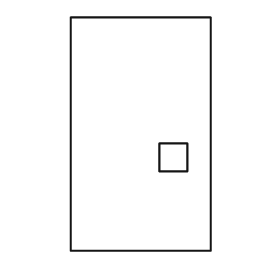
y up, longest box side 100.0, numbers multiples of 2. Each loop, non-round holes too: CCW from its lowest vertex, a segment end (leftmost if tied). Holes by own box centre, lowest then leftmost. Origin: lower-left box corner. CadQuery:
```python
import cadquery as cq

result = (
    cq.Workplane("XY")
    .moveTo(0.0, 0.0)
    .lineTo(60.0, 0.0)
    .lineTo(60.0, 100.0)
    .lineTo(0.0, 100.0)
    .close()
    .moveTo(38.0, 34.0)
    .lineTo(50.0, 34.0)
    .lineTo(50.0, 46.0)
    .lineTo(38.0, 46.0)
    .close()
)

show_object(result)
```